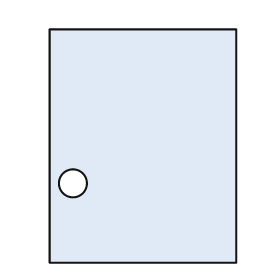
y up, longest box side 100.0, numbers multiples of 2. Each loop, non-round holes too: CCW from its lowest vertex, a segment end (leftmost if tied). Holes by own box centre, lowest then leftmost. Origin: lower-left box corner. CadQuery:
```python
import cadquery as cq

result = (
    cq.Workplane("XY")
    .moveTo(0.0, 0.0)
    .lineTo(80.0, 0.0)
    .lineTo(80.0, 100.0)
    .lineTo(0.0, 100.0)
    .close()
    .moveTo(10.0, 34.0)
    .circle(6.0)
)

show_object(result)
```